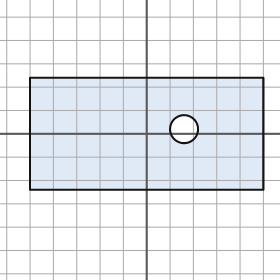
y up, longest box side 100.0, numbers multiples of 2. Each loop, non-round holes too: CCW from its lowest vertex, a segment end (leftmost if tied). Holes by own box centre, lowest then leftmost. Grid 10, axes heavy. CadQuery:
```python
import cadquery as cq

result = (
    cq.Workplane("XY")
    .moveTo(-50.0, -24.0)
    .lineTo(50.0, -24.0)
    .lineTo(50.0, 24.0)
    .lineTo(-50.0, 24.0)
    .close()
    .moveTo(16.0, 2.0)
    .circle(6.0)
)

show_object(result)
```